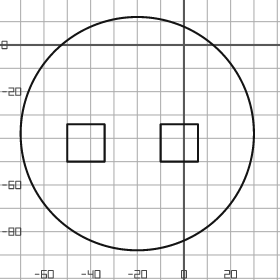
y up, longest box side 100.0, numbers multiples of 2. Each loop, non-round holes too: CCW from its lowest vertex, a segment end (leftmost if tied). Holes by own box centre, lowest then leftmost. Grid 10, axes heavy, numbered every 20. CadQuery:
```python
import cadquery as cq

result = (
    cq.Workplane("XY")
    .moveTo(-20.0, -38.0)
    .circle(50.0)
    .moveTo(-50.0, -50.0)
    .lineTo(-34.0, -50.0)
    .lineTo(-34.0, -34.0)
    .lineTo(-50.0, -34.0)
    .close()
    .moveTo(-10.0, -50.0)
    .lineTo(6.0, -50.0)
    .lineTo(6.0, -34.0)
    .lineTo(-10.0, -34.0)
    .close()
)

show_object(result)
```